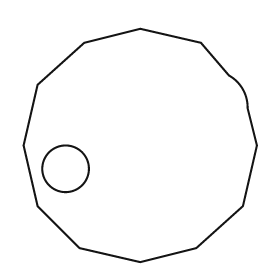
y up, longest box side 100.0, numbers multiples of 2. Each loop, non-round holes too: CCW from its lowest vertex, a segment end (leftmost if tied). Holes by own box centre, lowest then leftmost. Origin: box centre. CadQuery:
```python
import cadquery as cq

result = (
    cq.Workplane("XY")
    .moveTo(0.0, -50.0)
    .lineTo(24.0, -44.0)
    .lineTo(44.0, -26.0)
    .lineTo(50.0, 0.0)
    .lineTo(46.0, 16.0)
    .threePointArc((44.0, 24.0), (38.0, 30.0))
    .lineTo(26.0, 44.0)
    .lineTo(0.0, 50.0)
    .lineTo(-24.0, 44.0)
    .lineTo(-44.0, 26.0)
    .lineTo(-50.0, 0.0)
    .lineTo(-44.0, -26.0)
    .lineTo(-26.0, -44.0)
    .close()
    .moveTo(-32.0, -10.0)
    .circle(10.0)
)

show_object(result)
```